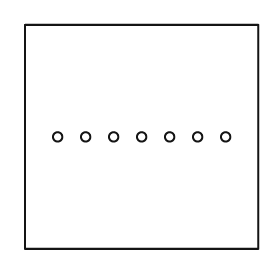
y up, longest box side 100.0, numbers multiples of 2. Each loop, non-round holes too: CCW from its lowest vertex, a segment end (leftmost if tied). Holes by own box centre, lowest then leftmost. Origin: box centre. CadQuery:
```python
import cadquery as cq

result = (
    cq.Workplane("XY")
    .moveTo(-50.0, -48.0)
    .lineTo(50.0, -48.0)
    .lineTo(50.0, 48.0)
    .lineTo(-50.0, 48.0)
    .close()
    .moveTo(-36.0, 0.0)
    .circle(2.0)
    .moveTo(-24.0, 0.0)
    .circle(2.0)
    .moveTo(-12.0, 0.0)
    .circle(2.0)
    .moveTo(0.0, 0.0)
    .circle(2.0)
    .moveTo(12.0, 0.0)
    .circle(2.0)
    .moveTo(24.0, 0.0)
    .circle(2.0)
    .moveTo(36.0, 0.0)
    .circle(2.0)
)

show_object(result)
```